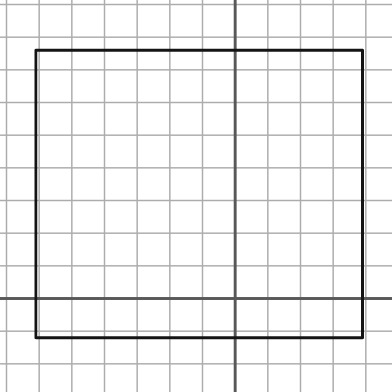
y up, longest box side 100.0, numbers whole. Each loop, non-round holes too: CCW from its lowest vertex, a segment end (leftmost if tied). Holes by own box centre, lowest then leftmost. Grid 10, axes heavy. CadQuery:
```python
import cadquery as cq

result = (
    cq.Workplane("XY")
    .moveTo(-61.0, -12.0)
    .lineTo(39.0, -12.0)
    .lineTo(39.0, 76.0)
    .lineTo(-61.0, 76.0)
    .close()
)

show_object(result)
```